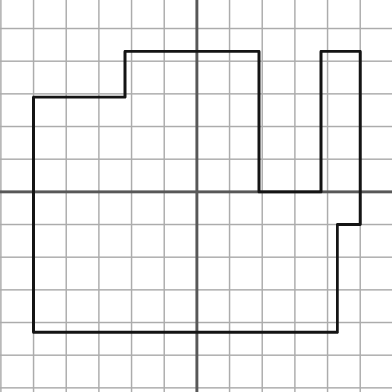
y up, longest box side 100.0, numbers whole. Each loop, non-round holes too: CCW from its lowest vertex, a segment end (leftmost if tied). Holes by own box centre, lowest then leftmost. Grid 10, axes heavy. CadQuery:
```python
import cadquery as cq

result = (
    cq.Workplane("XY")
    .moveTo(-50.0, -43.0)
    .lineTo(43.0, -43.0)
    .lineTo(43.0, -10.0)
    .lineTo(50.0, -10.0)
    .lineTo(50.0, 43.0)
    .lineTo(38.0, 43.0)
    .lineTo(38.0, 0.0)
    .lineTo(19.0, 0.0)
    .lineTo(19.0, 43.0)
    .lineTo(-22.0, 43.0)
    .lineTo(-22.0, 29.0)
    .lineTo(-50.0, 29.0)
    .close()
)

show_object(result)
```